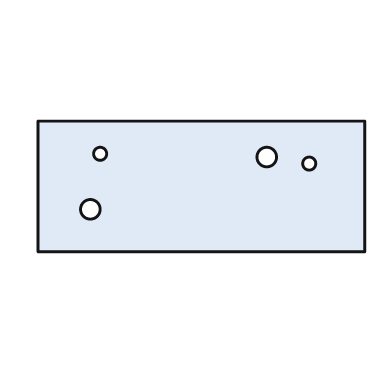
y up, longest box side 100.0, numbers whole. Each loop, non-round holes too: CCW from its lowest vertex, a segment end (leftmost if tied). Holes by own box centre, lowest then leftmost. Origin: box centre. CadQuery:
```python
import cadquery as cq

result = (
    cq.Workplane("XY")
    .moveTo(-50.0, -20.0)
    .lineTo(50.0, -20.0)
    .lineTo(50.0, 20.0)
    .lineTo(-50.0, 20.0)
    .close()
    .moveTo(-34.0, -7.0)
    .circle(3.0)
    .moveTo(33.0, 7.0)
    .circle(2.0)
    .moveTo(20.0, 9.0)
    .circle(3.0)
    .moveTo(-31.0, 10.0)
    .circle(2.0)
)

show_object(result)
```